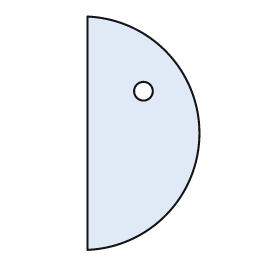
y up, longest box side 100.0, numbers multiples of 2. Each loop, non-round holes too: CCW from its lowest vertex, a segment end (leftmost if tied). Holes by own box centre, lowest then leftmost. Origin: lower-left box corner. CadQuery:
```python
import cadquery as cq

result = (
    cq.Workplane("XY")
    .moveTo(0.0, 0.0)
    .threePointArc((48.0, 50.0), (0.0, 100.0))
    .close()
    .moveTo(24.0, 68.0)
    .circle(4.0)
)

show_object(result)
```